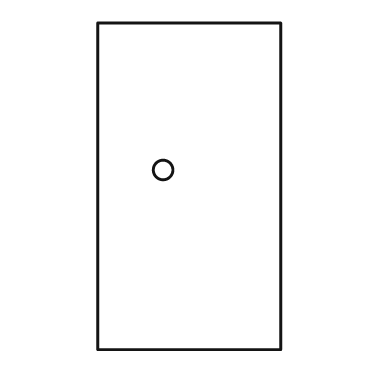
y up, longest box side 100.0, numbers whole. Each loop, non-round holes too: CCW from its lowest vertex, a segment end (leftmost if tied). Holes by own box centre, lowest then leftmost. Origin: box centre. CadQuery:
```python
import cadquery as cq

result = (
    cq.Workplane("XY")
    .moveTo(-28.0, -50.0)
    .lineTo(28.0, -50.0)
    .lineTo(28.0, 50.0)
    .lineTo(-28.0, 50.0)
    .close()
    .moveTo(-8.0, 5.0)
    .circle(3.0)
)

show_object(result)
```